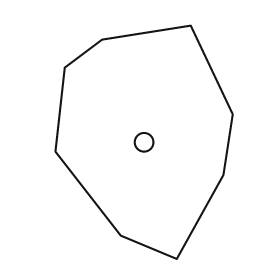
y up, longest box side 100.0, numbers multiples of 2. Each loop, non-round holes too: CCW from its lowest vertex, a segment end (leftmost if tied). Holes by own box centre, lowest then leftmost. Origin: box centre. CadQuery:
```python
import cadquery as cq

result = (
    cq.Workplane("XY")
    .moveTo(14.0, -50.0)
    .lineTo(34.0, -14.0)
    .lineTo(38.0, 12.0)
    .lineTo(20.0, 50.0)
    .lineTo(-18.0, 44.0)
    .lineTo(-34.0, 32.0)
    .lineTo(-38.0, -4.0)
    .lineTo(-10.0, -40.0)
    .close()
    .moveTo(0.0, 0.0)
    .circle(4.0)
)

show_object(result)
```